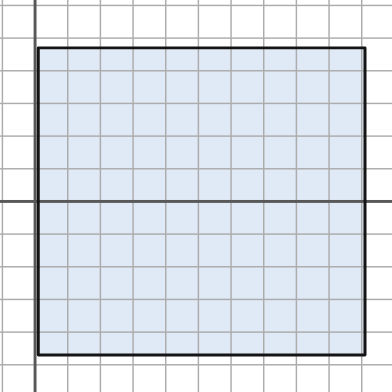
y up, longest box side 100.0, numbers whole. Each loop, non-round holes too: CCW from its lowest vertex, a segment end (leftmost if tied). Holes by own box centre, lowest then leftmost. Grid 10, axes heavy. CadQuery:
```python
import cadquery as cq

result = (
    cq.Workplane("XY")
    .moveTo(1.0, -47.0)
    .lineTo(101.0, -47.0)
    .lineTo(101.0, 47.0)
    .lineTo(1.0, 47.0)
    .close()
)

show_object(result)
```